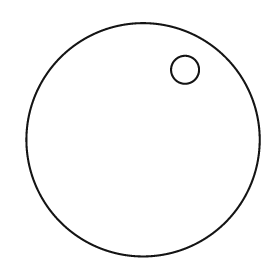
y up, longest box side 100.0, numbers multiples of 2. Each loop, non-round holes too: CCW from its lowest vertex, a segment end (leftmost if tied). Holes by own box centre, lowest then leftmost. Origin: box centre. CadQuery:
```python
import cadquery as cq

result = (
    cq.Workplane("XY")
    .moveTo(0.0, 0.0)
    .circle(50.0)
    .moveTo(18.0, 30.0)
    .circle(6.0)
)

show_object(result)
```